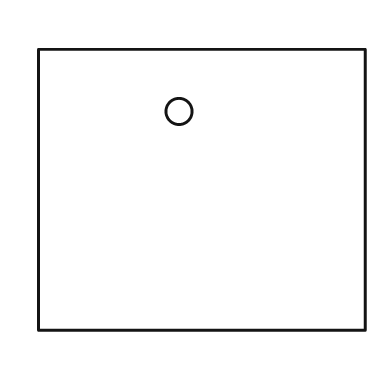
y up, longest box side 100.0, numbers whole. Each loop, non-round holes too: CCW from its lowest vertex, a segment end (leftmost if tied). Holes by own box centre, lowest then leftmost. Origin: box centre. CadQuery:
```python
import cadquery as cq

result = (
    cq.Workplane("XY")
    .moveTo(-50.0, -43.0)
    .lineTo(50.0, -43.0)
    .lineTo(50.0, 43.0)
    .lineTo(-50.0, 43.0)
    .close()
    .moveTo(-7.0, 24.0)
    .circle(4.0)
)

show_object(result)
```